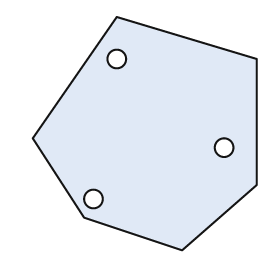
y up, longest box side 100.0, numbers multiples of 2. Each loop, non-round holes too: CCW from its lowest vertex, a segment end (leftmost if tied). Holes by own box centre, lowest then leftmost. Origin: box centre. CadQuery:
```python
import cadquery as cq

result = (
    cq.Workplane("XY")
    .moveTo(16.0, -50.0)
    .lineTo(48.0, -22.0)
    .lineTo(48.0, 32.0)
    .lineTo(-12.0, 50.0)
    .lineTo(-48.0, -2.0)
    .lineTo(-26.0, -36.0)
    .close()
    .moveTo(-22.0, -28.0)
    .circle(4.0)
    .moveTo(34.0, -6.0)
    .circle(4.0)
    .moveTo(-12.0, 32.0)
    .circle(4.0)
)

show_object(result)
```